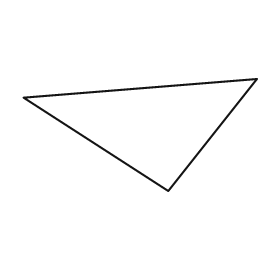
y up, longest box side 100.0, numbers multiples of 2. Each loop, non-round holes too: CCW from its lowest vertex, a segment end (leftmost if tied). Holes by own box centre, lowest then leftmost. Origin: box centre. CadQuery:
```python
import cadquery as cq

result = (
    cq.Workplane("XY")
    .moveTo(12.0, -24.0)
    .lineTo(50.0, 24.0)
    .lineTo(-50.0, 16.0)
    .close()
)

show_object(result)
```